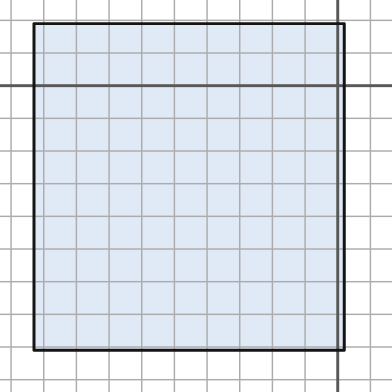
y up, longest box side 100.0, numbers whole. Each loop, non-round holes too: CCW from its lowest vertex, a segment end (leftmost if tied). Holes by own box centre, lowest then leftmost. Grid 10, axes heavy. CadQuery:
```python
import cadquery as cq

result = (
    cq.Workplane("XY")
    .moveTo(-93.0, -81.0)
    .lineTo(2.0, -81.0)
    .lineTo(2.0, 19.0)
    .lineTo(-93.0, 19.0)
    .close()
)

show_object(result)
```